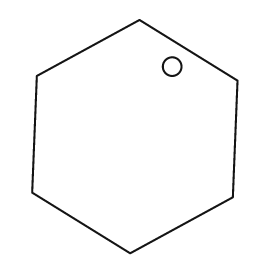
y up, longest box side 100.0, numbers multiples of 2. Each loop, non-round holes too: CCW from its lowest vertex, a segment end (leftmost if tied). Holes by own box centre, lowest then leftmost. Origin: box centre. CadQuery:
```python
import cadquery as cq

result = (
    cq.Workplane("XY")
    .moveTo(-2.0, -50.0)
    .lineTo(42.0, -26.0)
    .lineTo(44.0, 24.0)
    .lineTo(2.0, 50.0)
    .lineTo(-42.0, 26.0)
    .lineTo(-44.0, -24.0)
    .close()
    .moveTo(16.0, 30.0)
    .circle(4.0)
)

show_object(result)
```